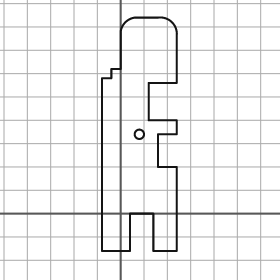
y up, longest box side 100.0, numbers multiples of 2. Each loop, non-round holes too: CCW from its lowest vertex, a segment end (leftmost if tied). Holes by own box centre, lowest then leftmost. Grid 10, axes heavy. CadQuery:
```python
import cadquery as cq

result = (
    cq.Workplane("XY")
    .moveTo(-8.0, -16.0)
    .lineTo(4.0, -16.0)
    .lineTo(4.0, 0.0)
    .lineTo(14.0, 0.0)
    .lineTo(14.0, -16.0)
    .lineTo(24.0, -16.0)
    .lineTo(24.0, 20.0)
    .lineTo(16.0, 20.0)
    .lineTo(16.0, 34.0)
    .lineTo(24.0, 34.0)
    .lineTo(24.0, 40.0)
    .lineTo(12.0, 40.0)
    .lineTo(12.0, 56.0)
    .lineTo(24.0, 56.0)
    .lineTo(24.0, 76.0)
    .threePointArc((22.0, 82.0), (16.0, 84.0))
    .lineTo(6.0, 84.0)
    .threePointArc((2.0, 82.0), (0.0, 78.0))
    .lineTo(0.0, 62.0)
    .lineTo(-4.0, 62.0)
    .lineTo(-4.0, 58.0)
    .lineTo(-8.0, 58.0)
    .close()
    .moveTo(8.0, 34.0)
    .circle(2.0)
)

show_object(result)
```